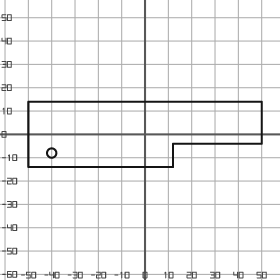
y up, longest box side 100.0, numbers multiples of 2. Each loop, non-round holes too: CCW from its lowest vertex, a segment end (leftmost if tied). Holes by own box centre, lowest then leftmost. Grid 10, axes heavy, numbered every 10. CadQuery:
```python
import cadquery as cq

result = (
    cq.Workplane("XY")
    .moveTo(-50.0, -14.0)
    .lineTo(12.0, -14.0)
    .lineTo(12.0, -4.0)
    .lineTo(50.0, -4.0)
    .lineTo(50.0, 14.0)
    .lineTo(-50.0, 14.0)
    .close()
    .moveTo(-40.0, -8.0)
    .circle(2.0)
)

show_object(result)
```